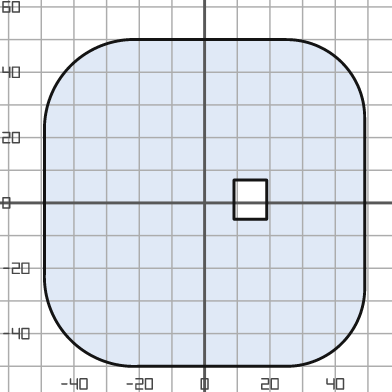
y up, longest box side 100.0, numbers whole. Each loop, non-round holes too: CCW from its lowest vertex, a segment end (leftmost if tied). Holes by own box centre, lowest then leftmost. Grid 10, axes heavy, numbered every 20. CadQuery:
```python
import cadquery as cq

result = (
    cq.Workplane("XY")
    .moveTo(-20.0, -50.0)
    .lineTo(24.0, -50.0)
    .threePointArc((42.0, -43.0), (49.0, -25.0))
    .lineTo(49.0, 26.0)
    .threePointArc((42.0, 43.0), (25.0, 50.0))
    .lineTo(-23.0, 50.0)
    .threePointArc((-41.0, 42.0), (-49.0, 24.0))
    .lineTo(-49.0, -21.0)
    .threePointArc((-41.0, -42.0), (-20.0, -50.0))
    .close()
    .moveTo(9.0, -5.0)
    .lineTo(19.0, -5.0)
    .lineTo(19.0, 7.0)
    .lineTo(9.0, 7.0)
    .close()
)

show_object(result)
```